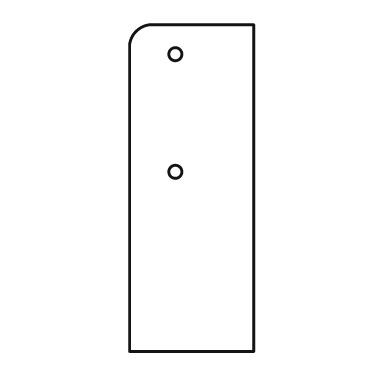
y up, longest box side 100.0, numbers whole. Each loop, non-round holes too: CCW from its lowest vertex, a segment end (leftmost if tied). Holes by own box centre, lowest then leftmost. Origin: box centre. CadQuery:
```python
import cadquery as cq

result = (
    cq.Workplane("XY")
    .moveTo(-19.0, -50.0)
    .lineTo(19.0, -50.0)
    .lineTo(19.0, 50.0)
    .lineTo(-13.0, 50.0)
    .threePointArc((-17.0, 48.0), (-19.0, 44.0))
    .close()
    .moveTo(-5.0, 5.0)
    .circle(2.0)
    .moveTo(-5.0, 41.0)
    .circle(2.0)
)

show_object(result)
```